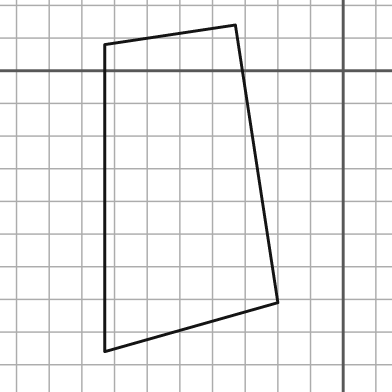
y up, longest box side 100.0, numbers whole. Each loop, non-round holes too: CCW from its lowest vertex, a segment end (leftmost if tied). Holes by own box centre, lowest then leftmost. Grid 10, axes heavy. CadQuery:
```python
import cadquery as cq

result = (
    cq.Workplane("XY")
    .moveTo(-73.0, -86.0)
    .lineTo(-20.0, -71.0)
    .lineTo(-33.0, 14.0)
    .lineTo(-73.0, 8.0)
    .close()
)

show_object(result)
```